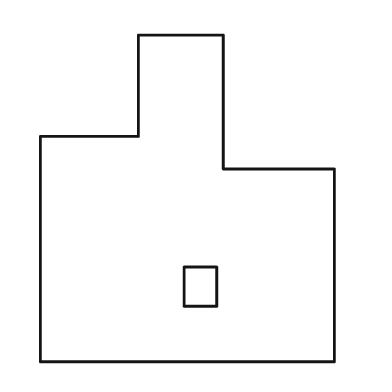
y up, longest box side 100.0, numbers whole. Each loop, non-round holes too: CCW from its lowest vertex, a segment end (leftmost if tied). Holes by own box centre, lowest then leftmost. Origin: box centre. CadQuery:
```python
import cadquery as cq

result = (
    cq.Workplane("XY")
    .moveTo(-45.0, -50.0)
    .lineTo(45.0, -50.0)
    .lineTo(45.0, 9.0)
    .lineTo(11.0, 9.0)
    .lineTo(11.0, 50.0)
    .lineTo(-15.0, 50.0)
    .lineTo(-15.0, 19.0)
    .lineTo(-45.0, 19.0)
    .close()
    .moveTo(-1.0, -33.0)
    .lineTo(9.0, -33.0)
    .lineTo(9.0, -21.0)
    .lineTo(-1.0, -21.0)
    .close()
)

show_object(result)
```